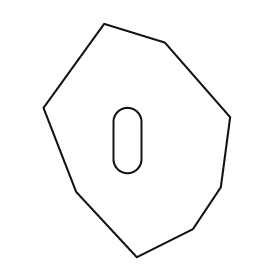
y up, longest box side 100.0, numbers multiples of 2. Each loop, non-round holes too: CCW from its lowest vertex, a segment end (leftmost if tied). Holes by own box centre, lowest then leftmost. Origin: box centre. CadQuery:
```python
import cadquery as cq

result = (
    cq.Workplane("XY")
    .moveTo(0.0, -50.0)
    .lineTo(24.0, -38.0)
    .lineTo(36.0, -20.0)
    .lineTo(40.0, 10.0)
    .lineTo(12.0, 42.0)
    .lineTo(-14.0, 50.0)
    .lineTo(-40.0, 14.0)
    .lineTo(-26.0, -22.0)
    .close()
    .moveTo(-10.0, -8.0)
    .threePointArc((-4.0, -14.0), (2.0, -8.0))
    .lineTo(2.0, 8.0)
    .threePointArc((-4.0, 14.0), (-10.0, 8.0))
    .close()
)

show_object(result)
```